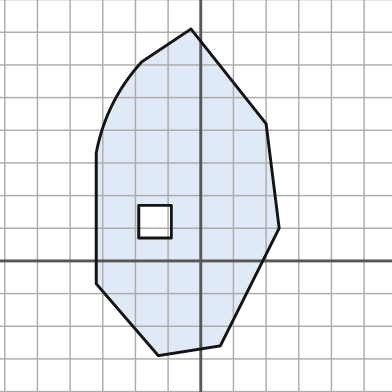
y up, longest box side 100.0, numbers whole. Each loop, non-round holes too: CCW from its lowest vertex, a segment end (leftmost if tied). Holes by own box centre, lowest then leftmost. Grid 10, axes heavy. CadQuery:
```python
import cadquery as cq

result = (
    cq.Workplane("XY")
    .moveTo(-13.0, -29.0)
    .lineTo(6.0, -26.0)
    .lineTo(24.0, 10.0)
    .lineTo(20.0, 42.0)
    .lineTo(-3.0, 71.0)
    .lineTo(-18.0, 61.0)
    .threePointArc((-27.0, 48.0), (-32.0, 33.0))
    .lineTo(-32.0, -7.0)
    .close()
    .moveTo(-19.0, 7.0)
    .lineTo(-9.0, 7.0)
    .lineTo(-9.0, 17.0)
    .lineTo(-19.0, 17.0)
    .close()
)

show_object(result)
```